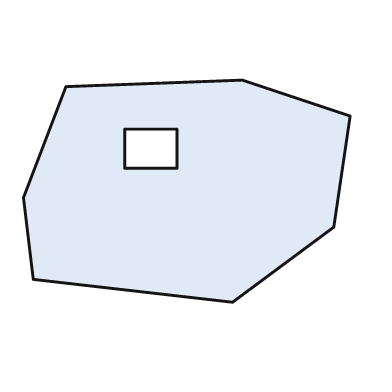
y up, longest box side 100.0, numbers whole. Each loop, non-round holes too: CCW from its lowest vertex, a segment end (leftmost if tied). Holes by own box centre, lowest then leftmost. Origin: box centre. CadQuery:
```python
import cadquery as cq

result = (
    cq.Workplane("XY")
    .moveTo(14.0, -34.0)
    .lineTo(45.0, -11.0)
    .lineTo(50.0, 23.0)
    .lineTo(17.0, 34.0)
    .lineTo(-37.0, 32.0)
    .lineTo(-50.0, -2.0)
    .lineTo(-47.0, -27.0)
    .close()
    .moveTo(-19.0, 7.0)
    .lineTo(-3.0, 7.0)
    .lineTo(-3.0, 19.0)
    .lineTo(-19.0, 19.0)
    .close()
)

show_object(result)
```